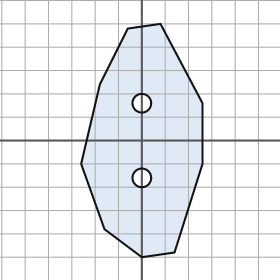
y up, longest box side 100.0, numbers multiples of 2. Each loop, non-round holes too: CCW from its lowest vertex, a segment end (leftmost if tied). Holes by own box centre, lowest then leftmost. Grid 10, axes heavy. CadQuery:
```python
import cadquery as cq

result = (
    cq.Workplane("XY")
    .moveTo(0.0, -50.0)
    .lineTo(14.0, -48.0)
    .lineTo(26.0, -10.0)
    .lineTo(26.0, 16.0)
    .lineTo(8.0, 50.0)
    .lineTo(-6.0, 48.0)
    .lineTo(-18.0, 24.0)
    .lineTo(-26.0, -10.0)
    .lineTo(-16.0, -38.0)
    .close()
    .moveTo(0.0, -16.0)
    .circle(4.0)
    .moveTo(0.0, 16.0)
    .circle(4.0)
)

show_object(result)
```